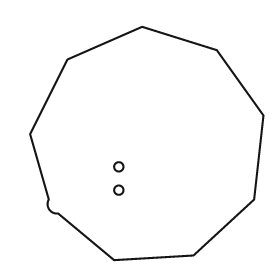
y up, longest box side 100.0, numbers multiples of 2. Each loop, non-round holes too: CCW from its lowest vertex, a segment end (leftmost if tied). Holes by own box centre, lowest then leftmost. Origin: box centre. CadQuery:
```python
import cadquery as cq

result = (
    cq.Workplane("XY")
    .moveTo(-14.0, -50.0)
    .lineTo(20.0, -48.0)
    .lineTo(46.0, -24.0)
    .lineTo(50.0, 12.0)
    .lineTo(30.0, 40.0)
    .lineTo(-2.0, 50.0)
    .lineTo(-34.0, 36.0)
    .lineTo(-50.0, 4.0)
    .lineTo(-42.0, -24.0)
    .threePointArc((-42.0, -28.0), (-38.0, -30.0))
    .close()
    .moveTo(-12.0, -20.0)
    .circle(2.0)
    .moveTo(-12.0, -10.0)
    .circle(2.0)
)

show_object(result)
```